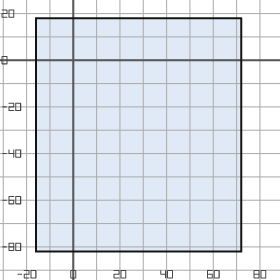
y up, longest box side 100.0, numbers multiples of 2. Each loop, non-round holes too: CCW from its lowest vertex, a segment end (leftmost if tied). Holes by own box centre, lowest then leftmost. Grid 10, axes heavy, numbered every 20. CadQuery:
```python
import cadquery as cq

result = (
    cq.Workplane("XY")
    .moveTo(-16.0, -82.0)
    .lineTo(72.0, -82.0)
    .lineTo(72.0, 18.0)
    .lineTo(-16.0, 18.0)
    .close()
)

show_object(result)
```